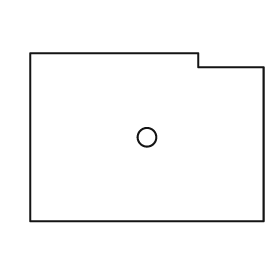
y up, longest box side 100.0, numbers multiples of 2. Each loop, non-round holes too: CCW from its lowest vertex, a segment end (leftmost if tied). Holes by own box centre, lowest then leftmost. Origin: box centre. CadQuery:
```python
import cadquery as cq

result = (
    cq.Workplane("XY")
    .moveTo(-50.0, -36.0)
    .lineTo(50.0, -36.0)
    .lineTo(50.0, 30.0)
    .lineTo(22.0, 30.0)
    .lineTo(22.0, 36.0)
    .lineTo(-50.0, 36.0)
    .close()
    .moveTo(0.0, 0.0)
    .circle(4.0)
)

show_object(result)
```